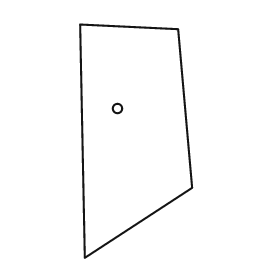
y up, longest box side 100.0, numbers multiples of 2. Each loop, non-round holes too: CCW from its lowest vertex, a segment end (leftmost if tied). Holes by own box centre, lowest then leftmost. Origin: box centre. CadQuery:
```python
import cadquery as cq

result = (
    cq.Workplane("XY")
    .moveTo(-22.0, -50.0)
    .lineTo(24.0, -20.0)
    .lineTo(18.0, 48.0)
    .lineTo(-24.0, 50.0)
    .close()
    .moveTo(-8.0, 14.0)
    .circle(2.0)
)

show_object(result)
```